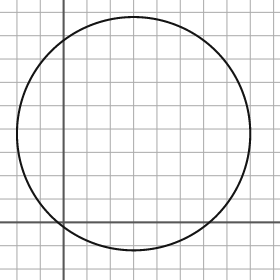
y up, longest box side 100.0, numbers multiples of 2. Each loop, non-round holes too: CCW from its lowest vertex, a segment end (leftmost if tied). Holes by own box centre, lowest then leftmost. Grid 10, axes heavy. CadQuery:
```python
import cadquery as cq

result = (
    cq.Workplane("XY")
    .moveTo(30.0, 38.0)
    .circle(50.0)
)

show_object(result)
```